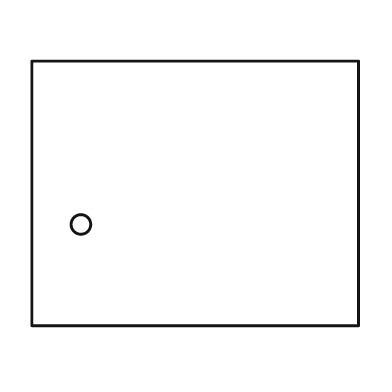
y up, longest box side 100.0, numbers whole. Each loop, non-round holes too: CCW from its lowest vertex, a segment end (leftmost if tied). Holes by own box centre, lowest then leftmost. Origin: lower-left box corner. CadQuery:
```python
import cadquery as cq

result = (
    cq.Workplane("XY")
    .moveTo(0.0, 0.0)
    .lineTo(100.0, 0.0)
    .lineTo(100.0, 81.0)
    .lineTo(0.0, 81.0)
    .close()
    .moveTo(15.0, 31.0)
    .circle(3.0)
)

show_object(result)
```